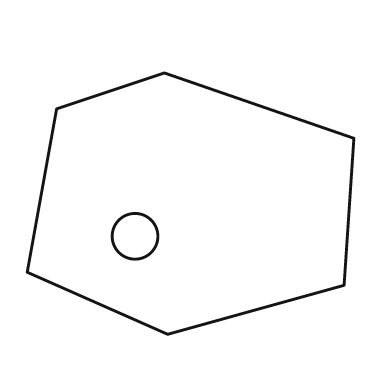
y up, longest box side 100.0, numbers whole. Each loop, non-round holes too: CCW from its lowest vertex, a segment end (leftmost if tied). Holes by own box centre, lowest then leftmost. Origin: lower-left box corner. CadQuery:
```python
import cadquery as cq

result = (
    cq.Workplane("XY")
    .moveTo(43.0, 0.0)
    .lineTo(97.0, 15.0)
    .lineTo(100.0, 60.0)
    .lineTo(42.0, 80.0)
    .lineTo(9.0, 69.0)
    .lineTo(0.0, 19.0)
    .close()
    .moveTo(33.0, 30.0)
    .circle(7.0)
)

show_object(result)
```